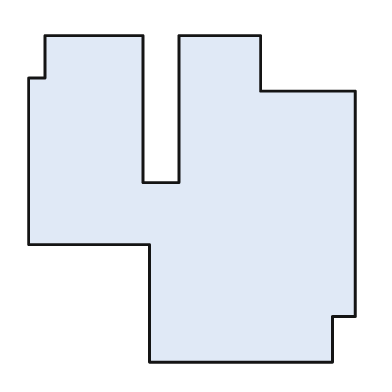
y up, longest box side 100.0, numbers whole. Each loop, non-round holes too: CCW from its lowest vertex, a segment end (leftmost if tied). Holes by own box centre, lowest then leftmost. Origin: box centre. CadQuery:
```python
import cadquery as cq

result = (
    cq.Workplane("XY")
    .moveTo(-13.0, -50.0)
    .lineTo(43.0, -50.0)
    .lineTo(43.0, -36.0)
    .lineTo(50.0, -36.0)
    .lineTo(50.0, 33.0)
    .lineTo(21.0, 33.0)
    .lineTo(21.0, 50.0)
    .lineTo(-4.0, 50.0)
    .lineTo(-4.0, 5.0)
    .lineTo(-15.0, 5.0)
    .lineTo(-15.0, 50.0)
    .lineTo(-45.0, 50.0)
    .lineTo(-45.0, 37.0)
    .lineTo(-50.0, 37.0)
    .lineTo(-50.0, -14.0)
    .lineTo(-13.0, -14.0)
    .close()
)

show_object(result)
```